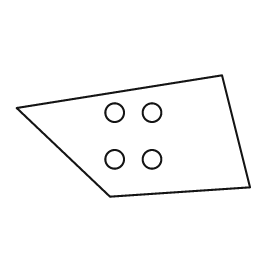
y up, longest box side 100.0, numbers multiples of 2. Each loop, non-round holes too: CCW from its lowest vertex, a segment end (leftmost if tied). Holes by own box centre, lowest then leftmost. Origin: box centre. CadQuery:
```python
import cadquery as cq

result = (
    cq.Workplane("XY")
    .moveTo(-10.0, -26.0)
    .lineTo(50.0, -22.0)
    .lineTo(38.0, 26.0)
    .lineTo(-50.0, 12.0)
    .close()
    .moveTo(-8.0, -10.0)
    .circle(4.0)
    .moveTo(8.0, -10.0)
    .circle(4.0)
    .moveTo(-8.0, 10.0)
    .circle(4.0)
    .moveTo(8.0, 10.0)
    .circle(4.0)
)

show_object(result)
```